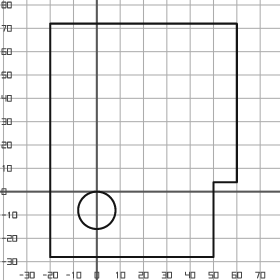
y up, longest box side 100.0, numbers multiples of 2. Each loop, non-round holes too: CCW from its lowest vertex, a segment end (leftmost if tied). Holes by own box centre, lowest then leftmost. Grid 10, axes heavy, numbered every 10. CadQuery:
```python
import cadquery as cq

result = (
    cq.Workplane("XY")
    .moveTo(-20.0, -28.0)
    .lineTo(50.0, -28.0)
    .lineTo(50.0, 4.0)
    .lineTo(60.0, 4.0)
    .lineTo(60.0, 72.0)
    .lineTo(-20.0, 72.0)
    .close()
    .moveTo(0.0, -8.0)
    .circle(8.0)
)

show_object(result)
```